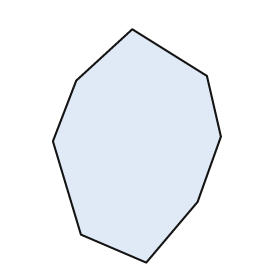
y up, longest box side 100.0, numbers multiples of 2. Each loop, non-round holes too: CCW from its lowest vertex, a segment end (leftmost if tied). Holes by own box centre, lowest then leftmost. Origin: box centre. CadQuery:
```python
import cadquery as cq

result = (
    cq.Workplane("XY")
    .moveTo(4.0, -50.0)
    .lineTo(26.0, -24.0)
    .lineTo(36.0, 4.0)
    .lineTo(30.0, 30.0)
    .lineTo(-2.0, 50.0)
    .lineTo(-26.0, 28.0)
    .lineTo(-36.0, 2.0)
    .lineTo(-24.0, -38.0)
    .close()
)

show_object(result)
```